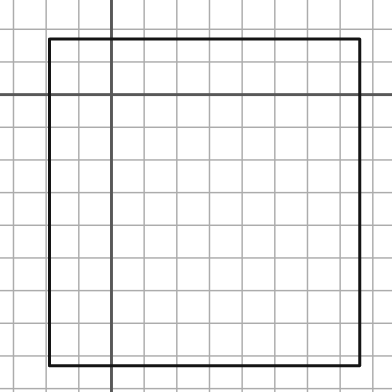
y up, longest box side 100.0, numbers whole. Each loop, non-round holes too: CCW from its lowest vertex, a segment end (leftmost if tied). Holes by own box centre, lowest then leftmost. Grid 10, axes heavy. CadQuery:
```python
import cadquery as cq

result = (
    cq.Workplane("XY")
    .moveTo(-19.0, -83.0)
    .lineTo(76.0, -83.0)
    .lineTo(76.0, 17.0)
    .lineTo(-19.0, 17.0)
    .close()
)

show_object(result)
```